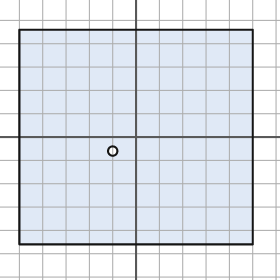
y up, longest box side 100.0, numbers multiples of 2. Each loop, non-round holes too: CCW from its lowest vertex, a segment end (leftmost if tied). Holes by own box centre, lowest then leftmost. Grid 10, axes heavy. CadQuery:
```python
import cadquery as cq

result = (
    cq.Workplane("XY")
    .moveTo(-50.0, -46.0)
    .lineTo(50.0, -46.0)
    .lineTo(50.0, 46.0)
    .lineTo(-50.0, 46.0)
    .close()
    .moveTo(-10.0, -6.0)
    .circle(2.0)
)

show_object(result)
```